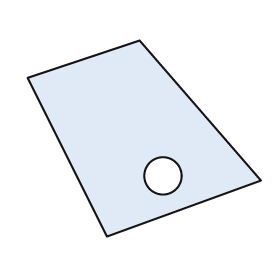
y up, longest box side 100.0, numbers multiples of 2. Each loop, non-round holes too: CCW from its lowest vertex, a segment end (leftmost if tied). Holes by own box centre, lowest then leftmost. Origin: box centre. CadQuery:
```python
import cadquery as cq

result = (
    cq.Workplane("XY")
    .moveTo(-16.0, -42.0)
    .lineTo(50.0, -18.0)
    .lineTo(-2.0, 42.0)
    .lineTo(-50.0, 26.0)
    .close()
    .moveTo(8.0, -16.0)
    .circle(8.0)
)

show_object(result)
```